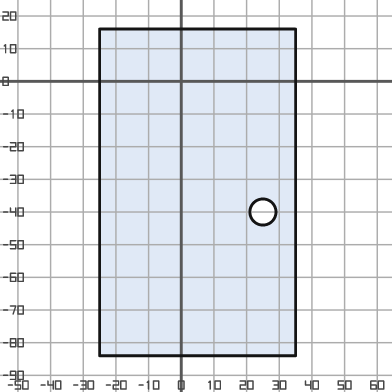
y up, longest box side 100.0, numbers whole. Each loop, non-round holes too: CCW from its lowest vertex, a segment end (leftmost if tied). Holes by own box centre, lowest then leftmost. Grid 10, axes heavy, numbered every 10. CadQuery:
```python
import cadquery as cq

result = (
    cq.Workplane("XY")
    .moveTo(-25.0, -84.0)
    .lineTo(35.0, -84.0)
    .lineTo(35.0, 16.0)
    .lineTo(-25.0, 16.0)
    .close()
    .moveTo(25.0, -40.0)
    .circle(4.0)
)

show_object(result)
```